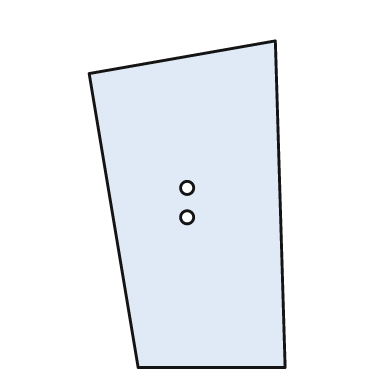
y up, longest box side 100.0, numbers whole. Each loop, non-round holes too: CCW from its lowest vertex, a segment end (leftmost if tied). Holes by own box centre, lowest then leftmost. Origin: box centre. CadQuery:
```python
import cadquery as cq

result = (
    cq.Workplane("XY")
    .moveTo(-15.0, -50.0)
    .lineTo(30.0, -50.0)
    .lineTo(27.0, 50.0)
    .lineTo(-30.0, 40.0)
    .close()
    .moveTo(0.0, -4.0)
    .circle(2.0)
    .moveTo(0.0, 5.0)
    .circle(2.0)
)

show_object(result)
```